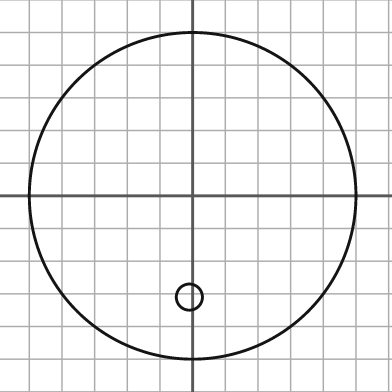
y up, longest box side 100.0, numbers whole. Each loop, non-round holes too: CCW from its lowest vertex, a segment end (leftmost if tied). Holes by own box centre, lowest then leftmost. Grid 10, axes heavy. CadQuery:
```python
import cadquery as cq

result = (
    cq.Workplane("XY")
    .moveTo(0.0, 0.0)
    .circle(50.0)
    .moveTo(-1.0, -31.0)
    .circle(4.0)
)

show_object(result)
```